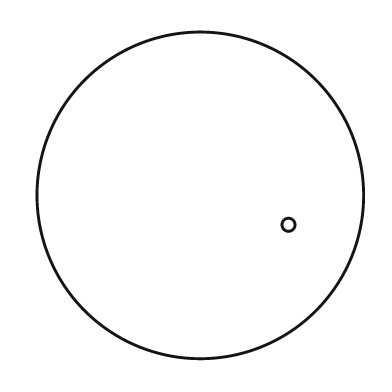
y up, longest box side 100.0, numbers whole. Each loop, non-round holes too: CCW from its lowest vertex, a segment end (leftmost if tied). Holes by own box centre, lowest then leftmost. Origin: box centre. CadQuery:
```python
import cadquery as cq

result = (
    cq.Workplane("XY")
    .moveTo(0.0, 0.0)
    .circle(50.0)
    .moveTo(27.0, -9.0)
    .circle(2.0)
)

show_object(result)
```